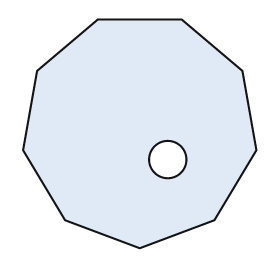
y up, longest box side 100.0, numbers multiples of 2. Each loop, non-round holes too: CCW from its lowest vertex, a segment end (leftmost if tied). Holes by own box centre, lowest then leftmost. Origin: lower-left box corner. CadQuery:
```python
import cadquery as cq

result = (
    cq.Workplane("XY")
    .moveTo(50.0, 0.0)
    .lineTo(82.0, 12.0)
    .lineTo(100.0, 42.0)
    .lineTo(94.0, 76.0)
    .lineTo(68.0, 98.0)
    .lineTo(32.0, 98.0)
    .lineTo(6.0, 76.0)
    .lineTo(0.0, 42.0)
    .lineTo(18.0, 12.0)
    .close()
    .moveTo(62.0, 38.0)
    .circle(8.0)
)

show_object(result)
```